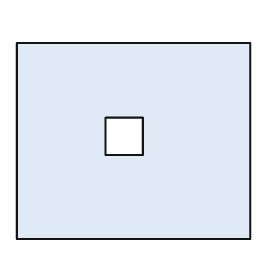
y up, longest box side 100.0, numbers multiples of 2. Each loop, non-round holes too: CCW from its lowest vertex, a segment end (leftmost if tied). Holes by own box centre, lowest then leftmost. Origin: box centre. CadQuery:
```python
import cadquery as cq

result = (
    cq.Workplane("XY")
    .moveTo(-50.0, -42.0)
    .lineTo(50.0, -42.0)
    .lineTo(50.0, 42.0)
    .lineTo(-50.0, 42.0)
    .close()
    .moveTo(-12.0, -6.0)
    .lineTo(4.0, -6.0)
    .lineTo(4.0, 10.0)
    .lineTo(-12.0, 10.0)
    .close()
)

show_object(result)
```